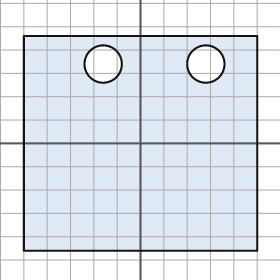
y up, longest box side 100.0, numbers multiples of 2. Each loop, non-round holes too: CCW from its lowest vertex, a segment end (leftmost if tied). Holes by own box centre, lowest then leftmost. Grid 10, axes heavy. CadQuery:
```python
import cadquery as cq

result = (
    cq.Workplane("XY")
    .moveTo(-50.0, -46.0)
    .lineTo(50.0, -46.0)
    .lineTo(50.0, 46.0)
    .lineTo(-50.0, 46.0)
    .close()
    .moveTo(-16.0, 34.0)
    .circle(8.0)
    .moveTo(28.0, 34.0)
    .circle(8.0)
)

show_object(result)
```